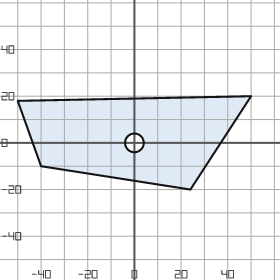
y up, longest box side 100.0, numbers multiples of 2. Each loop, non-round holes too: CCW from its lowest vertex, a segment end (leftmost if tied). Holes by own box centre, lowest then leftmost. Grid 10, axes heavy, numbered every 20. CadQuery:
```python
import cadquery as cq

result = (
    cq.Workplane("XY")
    .moveTo(24.0, -20.0)
    .lineTo(50.0, 20.0)
    .lineTo(-50.0, 18.0)
    .lineTo(-40.0, -10.0)
    .close()
    .moveTo(0.0, 0.0)
    .circle(4.0)
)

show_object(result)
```